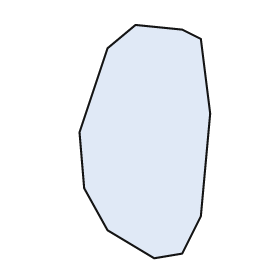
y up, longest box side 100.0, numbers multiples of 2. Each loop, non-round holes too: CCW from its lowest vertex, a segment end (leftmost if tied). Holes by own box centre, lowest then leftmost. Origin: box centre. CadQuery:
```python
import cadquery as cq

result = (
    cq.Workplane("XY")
    .moveTo(4.0, -50.0)
    .lineTo(16.0, -48.0)
    .lineTo(24.0, -32.0)
    .lineTo(28.0, 12.0)
    .lineTo(24.0, 44.0)
    .lineTo(16.0, 48.0)
    .lineTo(-4.0, 50.0)
    .lineTo(-16.0, 40.0)
    .lineTo(-28.0, 4.0)
    .lineTo(-26.0, -20.0)
    .lineTo(-16.0, -38.0)
    .close()
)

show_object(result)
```